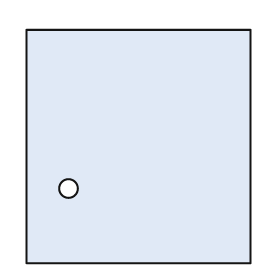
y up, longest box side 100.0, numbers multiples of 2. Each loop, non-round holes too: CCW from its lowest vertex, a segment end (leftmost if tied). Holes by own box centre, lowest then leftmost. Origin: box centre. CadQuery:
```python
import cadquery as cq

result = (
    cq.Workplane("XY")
    .moveTo(-48.0, -50.0)
    .lineTo(48.0, -50.0)
    .lineTo(48.0, 50.0)
    .lineTo(-48.0, 50.0)
    .close()
    .moveTo(-30.0, -18.0)
    .circle(4.0)
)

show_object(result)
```